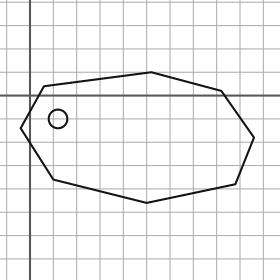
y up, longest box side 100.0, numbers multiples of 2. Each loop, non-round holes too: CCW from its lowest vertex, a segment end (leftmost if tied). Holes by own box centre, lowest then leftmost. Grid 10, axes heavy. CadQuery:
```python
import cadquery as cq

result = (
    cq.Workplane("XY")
    .moveTo(50.0, -46.0)
    .lineTo(88.0, -38.0)
    .lineTo(96.0, -18.0)
    .lineTo(82.0, 2.0)
    .lineTo(52.0, 10.0)
    .lineTo(6.0, 4.0)
    .lineTo(-4.0, -14.0)
    .lineTo(10.0, -36.0)
    .close()
    .moveTo(12.0, -10.0)
    .circle(4.0)
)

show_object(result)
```